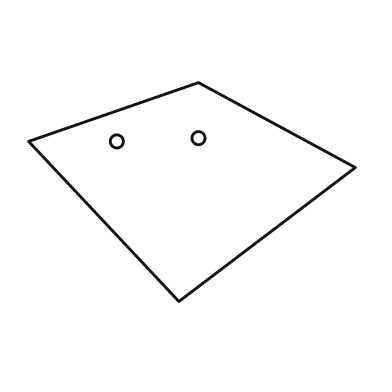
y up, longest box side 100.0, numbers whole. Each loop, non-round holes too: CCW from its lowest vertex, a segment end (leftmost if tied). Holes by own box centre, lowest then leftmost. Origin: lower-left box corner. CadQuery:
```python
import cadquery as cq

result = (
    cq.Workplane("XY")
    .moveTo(46.0, 0.0)
    .lineTo(100.0, 41.0)
    .lineTo(52.0, 67.0)
    .lineTo(0.0, 49.0)
    .close()
    .moveTo(27.0, 49.0)
    .circle(2.0)
    .moveTo(52.0, 50.0)
    .circle(2.0)
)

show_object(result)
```